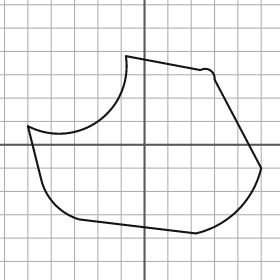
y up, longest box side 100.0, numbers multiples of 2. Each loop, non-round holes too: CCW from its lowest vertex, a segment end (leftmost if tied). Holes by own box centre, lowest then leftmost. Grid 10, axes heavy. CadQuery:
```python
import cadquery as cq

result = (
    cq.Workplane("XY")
    .moveTo(22.0, -38.0)
    .threePointArc((40.0, -28.0), (50.0, -10.0))
    .lineTo(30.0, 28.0)
    .threePointArc((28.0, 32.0), (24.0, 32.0))
    .lineTo(-8.0, 38.0)
    .threePointArc((-20.0, 10.0), (-50.0, 8.0))
    .lineTo(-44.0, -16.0)
    .threePointArc((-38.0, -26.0), (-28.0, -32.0))
    .close()
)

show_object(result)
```